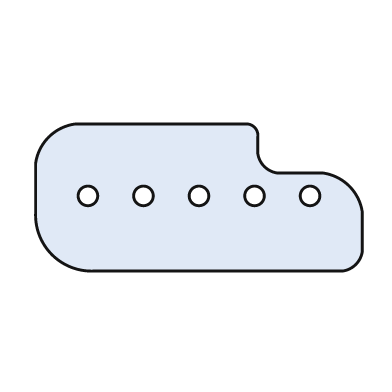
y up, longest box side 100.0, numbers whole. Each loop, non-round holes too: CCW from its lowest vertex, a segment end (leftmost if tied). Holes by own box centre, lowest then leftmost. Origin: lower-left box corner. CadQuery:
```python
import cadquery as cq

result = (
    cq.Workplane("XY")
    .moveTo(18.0, 0.0)
    .lineTo(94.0, 0.0)
    .threePointArc((98.0, 2.0), (100.0, 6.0))
    .lineTo(100.0, 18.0)
    .threePointArc((96.0, 26.0), (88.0, 30.0))
    .lineTo(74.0, 30.0)
    .threePointArc((70.0, 32.0), (68.0, 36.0))
    .lineTo(68.0, 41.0)
    .threePointArc((67.0, 44.0), (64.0, 45.0))
    .lineTo(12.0, 45.0)
    .threePointArc((4.0, 41.0), (0.0, 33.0))
    .lineTo(0.0, 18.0)
    .threePointArc((5.0, 5.0), (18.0, 0.0))
    .close()
    .moveTo(16.0, 23.0)
    .circle(3.0)
    .moveTo(33.0, 23.0)
    .circle(3.0)
    .moveTo(50.0, 23.0)
    .circle(3.0)
    .moveTo(67.0, 23.0)
    .circle(3.0)
    .moveTo(84.0, 23.0)
    .circle(3.0)
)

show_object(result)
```